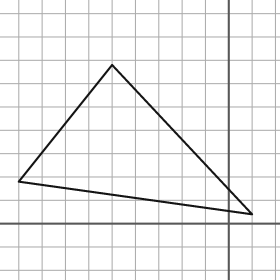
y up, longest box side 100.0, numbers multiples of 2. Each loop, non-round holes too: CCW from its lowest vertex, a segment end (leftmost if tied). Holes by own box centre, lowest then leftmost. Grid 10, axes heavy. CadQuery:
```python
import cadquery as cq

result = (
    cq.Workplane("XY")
    .moveTo(10.0, 4.0)
    .lineTo(-50.0, 68.0)
    .lineTo(-90.0, 18.0)
    .close()
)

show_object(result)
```